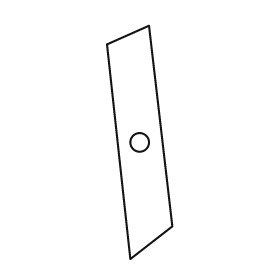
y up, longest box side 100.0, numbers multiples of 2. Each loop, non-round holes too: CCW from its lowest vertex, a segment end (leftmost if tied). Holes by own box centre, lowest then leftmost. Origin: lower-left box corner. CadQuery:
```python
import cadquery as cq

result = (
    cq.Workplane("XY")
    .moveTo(10.0, 0.0)
    .lineTo(28.0, 14.0)
    .lineTo(18.0, 100.0)
    .lineTo(0.0, 92.0)
    .close()
    .moveTo(14.0, 50.0)
    .circle(4.0)
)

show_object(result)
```